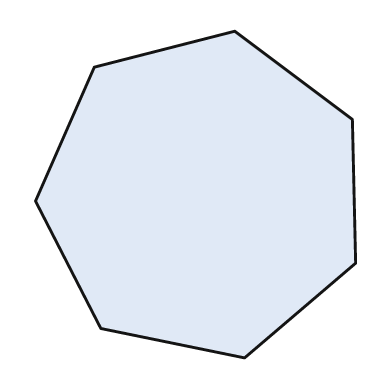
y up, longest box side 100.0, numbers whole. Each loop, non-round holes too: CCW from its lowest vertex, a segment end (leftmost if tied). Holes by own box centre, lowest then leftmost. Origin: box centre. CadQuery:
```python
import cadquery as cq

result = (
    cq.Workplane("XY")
    .moveTo(15.0, -50.0)
    .lineTo(49.0, -21.0)
    .lineTo(48.0, 23.0)
    .lineTo(12.0, 50.0)
    .lineTo(-31.0, 39.0)
    .lineTo(-49.0, -2.0)
    .lineTo(-29.0, -41.0)
    .close()
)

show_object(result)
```